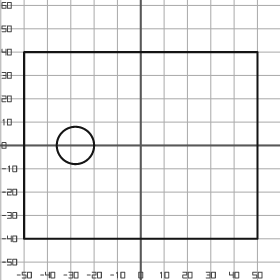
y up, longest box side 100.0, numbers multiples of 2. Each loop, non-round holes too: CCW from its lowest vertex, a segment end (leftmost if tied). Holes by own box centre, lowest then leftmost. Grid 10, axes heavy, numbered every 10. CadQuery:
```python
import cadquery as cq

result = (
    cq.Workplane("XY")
    .moveTo(-50.0, -40.0)
    .lineTo(50.0, -40.0)
    .lineTo(50.0, 40.0)
    .lineTo(-50.0, 40.0)
    .close()
    .moveTo(-28.0, 0.0)
    .circle(8.0)
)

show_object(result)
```